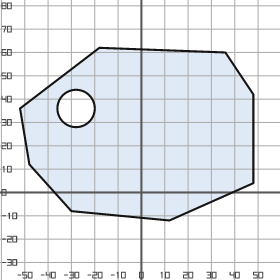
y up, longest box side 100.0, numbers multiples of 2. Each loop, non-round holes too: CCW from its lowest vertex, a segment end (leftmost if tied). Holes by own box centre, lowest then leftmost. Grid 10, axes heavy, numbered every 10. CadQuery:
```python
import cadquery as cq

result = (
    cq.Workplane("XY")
    .moveTo(12.0, -12.0)
    .lineTo(48.0, 4.0)
    .lineTo(48.0, 42.0)
    .lineTo(36.0, 60.0)
    .lineTo(-18.0, 62.0)
    .lineTo(-52.0, 36.0)
    .lineTo(-48.0, 12.0)
    .lineTo(-30.0, -8.0)
    .close()
    .moveTo(-28.0, 36.0)
    .circle(8.0)
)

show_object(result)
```